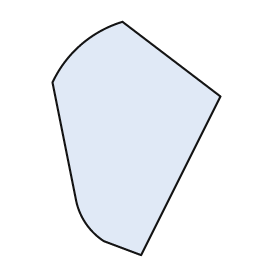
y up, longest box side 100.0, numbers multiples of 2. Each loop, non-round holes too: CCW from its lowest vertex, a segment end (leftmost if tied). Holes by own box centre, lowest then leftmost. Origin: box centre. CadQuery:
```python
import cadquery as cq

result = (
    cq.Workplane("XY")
    .moveTo(2.0, -50.0)
    .lineTo(36.0, 18.0)
    .lineTo(-6.0, 50.0)
    .threePointArc((-24.0, 40.0), (-36.0, 24.0))
    .lineTo(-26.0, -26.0)
    .threePointArc((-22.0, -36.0), (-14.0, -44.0))
    .close()
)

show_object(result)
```